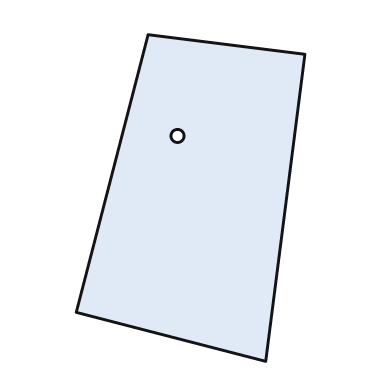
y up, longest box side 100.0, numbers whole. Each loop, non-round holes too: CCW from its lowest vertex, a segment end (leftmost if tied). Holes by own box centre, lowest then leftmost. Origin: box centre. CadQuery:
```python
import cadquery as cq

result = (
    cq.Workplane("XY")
    .moveTo(23.0, -50.0)
    .lineTo(35.0, 44.0)
    .lineTo(-13.0, 50.0)
    .lineTo(-35.0, -35.0)
    .close()
    .moveTo(-4.0, 19.0)
    .circle(2.0)
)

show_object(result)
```